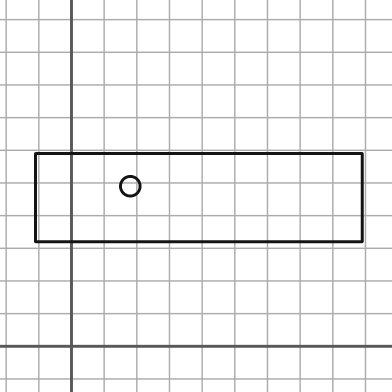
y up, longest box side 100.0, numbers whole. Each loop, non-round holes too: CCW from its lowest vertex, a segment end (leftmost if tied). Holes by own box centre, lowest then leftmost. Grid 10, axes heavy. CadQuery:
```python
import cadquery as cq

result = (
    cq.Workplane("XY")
    .moveTo(-11.0, 32.0)
    .lineTo(89.0, 32.0)
    .lineTo(89.0, 59.0)
    .lineTo(-11.0, 59.0)
    .close()
    .moveTo(18.0, 49.0)
    .circle(3.0)
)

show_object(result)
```